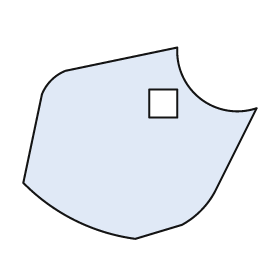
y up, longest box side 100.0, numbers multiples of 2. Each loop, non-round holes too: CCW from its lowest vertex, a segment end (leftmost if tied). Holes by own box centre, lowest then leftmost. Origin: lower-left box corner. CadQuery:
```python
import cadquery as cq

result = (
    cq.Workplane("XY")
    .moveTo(48.0, 0.0)
    .lineTo(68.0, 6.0)
    .threePointArc((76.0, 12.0), (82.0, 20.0))
    .lineTo(100.0, 56.0)
    .threePointArc((76.0, 60.0), (66.0, 82.0))
    .lineTo(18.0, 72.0)
    .threePointArc((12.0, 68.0), (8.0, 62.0))
    .lineTo(0.0, 24.0)
    .threePointArc((22.0, 8.0), (48.0, 0.0))
    .close()
    .moveTo(54.0, 52.0)
    .lineTo(66.0, 52.0)
    .lineTo(66.0, 64.0)
    .lineTo(54.0, 64.0)
    .close()
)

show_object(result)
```